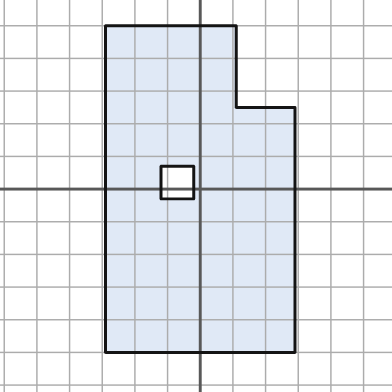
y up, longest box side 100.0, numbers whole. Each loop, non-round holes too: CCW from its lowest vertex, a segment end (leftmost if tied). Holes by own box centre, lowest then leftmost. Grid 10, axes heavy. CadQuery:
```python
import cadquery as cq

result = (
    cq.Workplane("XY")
    .moveTo(-29.0, -50.0)
    .lineTo(29.0, -50.0)
    .lineTo(29.0, 25.0)
    .lineTo(11.0, 25.0)
    .lineTo(11.0, 50.0)
    .lineTo(-29.0, 50.0)
    .close()
    .moveTo(-12.0, -3.0)
    .lineTo(-2.0, -3.0)
    .lineTo(-2.0, 7.0)
    .lineTo(-12.0, 7.0)
    .close()
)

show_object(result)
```